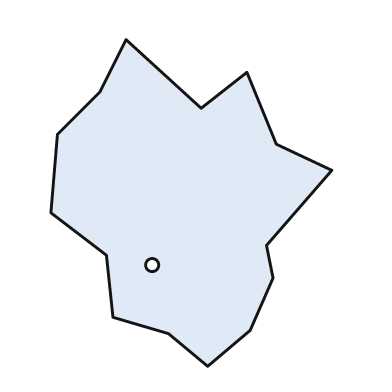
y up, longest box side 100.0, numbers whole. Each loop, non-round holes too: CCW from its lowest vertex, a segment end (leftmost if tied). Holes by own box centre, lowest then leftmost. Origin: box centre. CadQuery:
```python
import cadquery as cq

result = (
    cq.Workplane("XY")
    .moveTo(5.0, -50.0)
    .lineTo(18.0, -39.0)
    .lineTo(25.0, -23.0)
    .lineTo(23.0, -13.0)
    .lineTo(43.0, 10.0)
    .lineTo(26.0, 18.0)
    .lineTo(17.0, 40.0)
    .lineTo(3.0, 29.0)
    .lineTo(-20.0, 50.0)
    .lineTo(-28.0, 34.0)
    .lineTo(-41.0, 21.0)
    .lineTo(-43.0, -3.0)
    .lineTo(-26.0, -16.0)
    .lineTo(-24.0, -35.0)
    .lineTo(-7.0, -40.0)
    .close()
    .moveTo(-12.0, -19.0)
    .circle(2.0)
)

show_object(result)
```